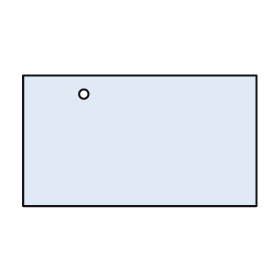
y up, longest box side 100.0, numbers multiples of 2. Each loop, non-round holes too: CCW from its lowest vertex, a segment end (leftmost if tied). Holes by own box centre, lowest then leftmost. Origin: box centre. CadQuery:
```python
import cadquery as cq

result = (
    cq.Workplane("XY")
    .moveTo(-50.0, -28.0)
    .lineTo(50.0, -28.0)
    .lineTo(50.0, 28.0)
    .lineTo(-50.0, 28.0)
    .close()
    .moveTo(-24.0, 20.0)
    .circle(2.0)
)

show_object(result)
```